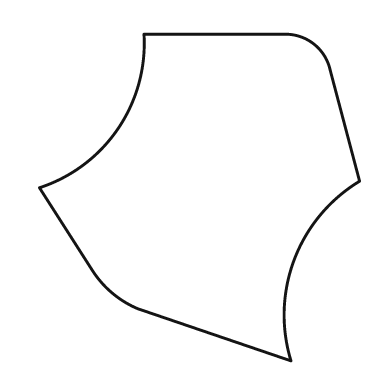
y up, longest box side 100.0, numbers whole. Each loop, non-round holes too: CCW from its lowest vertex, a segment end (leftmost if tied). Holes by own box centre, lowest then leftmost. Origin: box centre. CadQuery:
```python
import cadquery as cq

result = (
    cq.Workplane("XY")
    .moveTo(28.0, -50.0)
    .threePointArc((29.0, -19.0), (49.0, 5.0))
    .lineTo(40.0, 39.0)
    .threePointArc((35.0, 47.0), (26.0, 50.0))
    .lineTo(-17.0, 50.0)
    .threePointArc((-25.0, 21.0), (-49.0, 3.0))
    .lineTo(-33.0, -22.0)
    .threePointArc((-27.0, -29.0), (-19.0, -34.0))
    .close()
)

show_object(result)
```